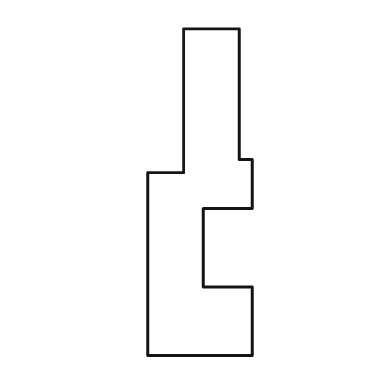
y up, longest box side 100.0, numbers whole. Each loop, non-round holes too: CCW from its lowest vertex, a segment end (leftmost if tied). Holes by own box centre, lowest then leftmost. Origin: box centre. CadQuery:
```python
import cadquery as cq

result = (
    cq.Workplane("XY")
    .moveTo(-16.0, -50.0)
    .lineTo(16.0, -50.0)
    .lineTo(16.0, -29.0)
    .lineTo(1.0, -29.0)
    .lineTo(1.0, -5.0)
    .lineTo(16.0, -5.0)
    .lineTo(16.0, 10.0)
    .lineTo(12.0, 10.0)
    .lineTo(12.0, 50.0)
    .lineTo(-5.0, 50.0)
    .lineTo(-5.0, 6.0)
    .lineTo(-16.0, 6.0)
    .close()
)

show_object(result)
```